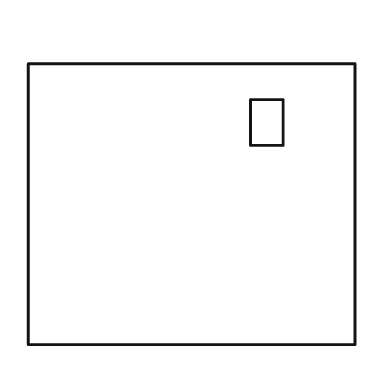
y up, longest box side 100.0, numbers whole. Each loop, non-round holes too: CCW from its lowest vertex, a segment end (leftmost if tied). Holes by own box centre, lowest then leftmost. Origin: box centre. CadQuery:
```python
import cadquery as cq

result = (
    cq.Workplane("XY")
    .moveTo(-50.0, -43.0)
    .lineTo(50.0, -43.0)
    .lineTo(50.0, 43.0)
    .lineTo(-50.0, 43.0)
    .close()
    .moveTo(18.0, 18.0)
    .lineTo(28.0, 18.0)
    .lineTo(28.0, 32.0)
    .lineTo(18.0, 32.0)
    .close()
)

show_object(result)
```